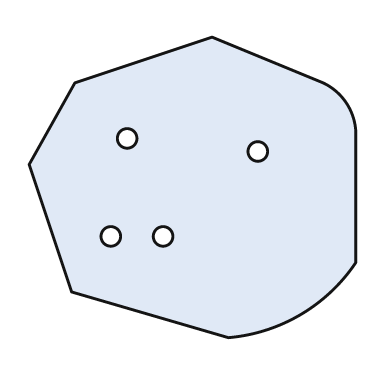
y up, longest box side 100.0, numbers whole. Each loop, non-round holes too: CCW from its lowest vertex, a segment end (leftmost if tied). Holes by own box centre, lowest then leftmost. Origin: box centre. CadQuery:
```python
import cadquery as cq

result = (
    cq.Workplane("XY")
    .moveTo(11.0, -46.0)
    .threePointArc((33.0, -39.0), (50.0, -23.0))
    .lineTo(50.0, 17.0)
    .threePointArc((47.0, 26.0), (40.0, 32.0))
    .lineTo(6.0, 46.0)
    .lineTo(-36.0, 32.0)
    .lineTo(-50.0, 7.0)
    .lineTo(-37.0, -32.0)
    .close()
    .moveTo(-25.0, -15.0)
    .circle(3.0)
    .moveTo(-9.0, -15.0)
    .circle(3.0)
    .moveTo(20.0, 11.0)
    .circle(3.0)
    .moveTo(-20.0, 15.0)
    .circle(3.0)
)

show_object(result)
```